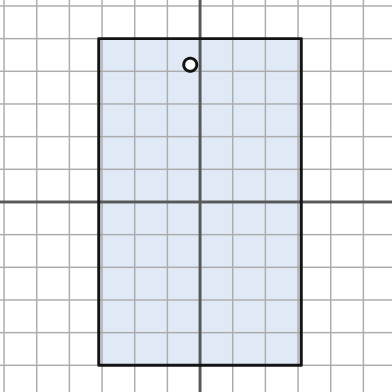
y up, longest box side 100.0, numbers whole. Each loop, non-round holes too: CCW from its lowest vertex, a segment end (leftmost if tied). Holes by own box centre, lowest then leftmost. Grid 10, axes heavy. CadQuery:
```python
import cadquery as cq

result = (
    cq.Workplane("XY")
    .moveTo(-31.0, -50.0)
    .lineTo(31.0, -50.0)
    .lineTo(31.0, 50.0)
    .lineTo(-31.0, 50.0)
    .close()
    .moveTo(-3.0, 42.0)
    .circle(2.0)
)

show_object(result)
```